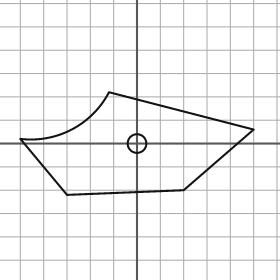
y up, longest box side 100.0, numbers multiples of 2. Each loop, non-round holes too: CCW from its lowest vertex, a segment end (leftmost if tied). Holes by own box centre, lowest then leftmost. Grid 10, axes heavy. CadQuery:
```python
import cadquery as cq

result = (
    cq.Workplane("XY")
    .moveTo(-30.0, -22.0)
    .lineTo(20.0, -20.0)
    .lineTo(50.0, 6.0)
    .lineTo(-12.0, 22.0)
    .threePointArc((-28.0, 6.0), (-50.0, 2.0))
    .close()
    .moveTo(0.0, 0.0)
    .circle(4.0)
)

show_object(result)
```